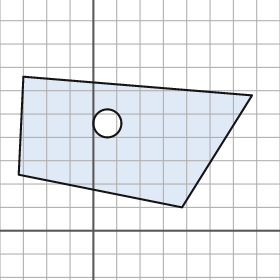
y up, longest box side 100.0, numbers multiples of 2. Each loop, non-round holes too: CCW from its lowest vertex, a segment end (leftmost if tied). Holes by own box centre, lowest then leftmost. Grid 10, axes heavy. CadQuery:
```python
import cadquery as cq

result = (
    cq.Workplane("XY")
    .moveTo(38.0, 10.0)
    .lineTo(68.0, 58.0)
    .lineTo(-30.0, 66.0)
    .lineTo(-32.0, 24.0)
    .close()
    .moveTo(6.0, 46.0)
    .circle(6.0)
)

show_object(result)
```